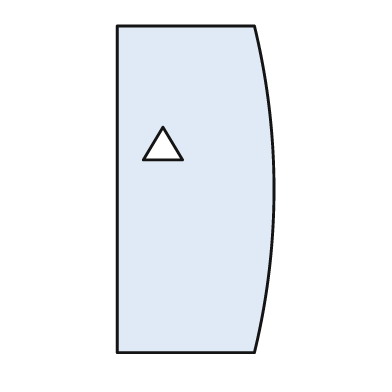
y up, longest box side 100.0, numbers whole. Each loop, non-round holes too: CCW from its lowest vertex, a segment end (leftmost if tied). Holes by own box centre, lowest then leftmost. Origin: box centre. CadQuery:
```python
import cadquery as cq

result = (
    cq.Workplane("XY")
    .moveTo(-24.0, -50.0)
    .lineTo(18.0, -50.0)
    .threePointArc((24.0, 0.0), (18.0, 50.0))
    .lineTo(-24.0, 50.0)
    .close()
    .moveTo(-16.0, 9.0)
    .lineTo(-4.0, 9.0)
    .lineTo(-10.0, 19.0)
    .close()
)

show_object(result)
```